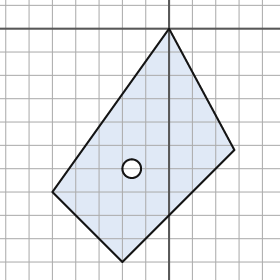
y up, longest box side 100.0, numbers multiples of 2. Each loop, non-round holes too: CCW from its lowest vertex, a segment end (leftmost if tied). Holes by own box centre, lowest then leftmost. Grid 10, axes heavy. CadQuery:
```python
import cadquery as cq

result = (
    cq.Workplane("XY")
    .moveTo(-20.0, -100.0)
    .lineTo(28.0, -52.0)
    .lineTo(0.0, 0.0)
    .lineTo(-50.0, -70.0)
    .close()
    .moveTo(-16.0, -60.0)
    .circle(4.0)
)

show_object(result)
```